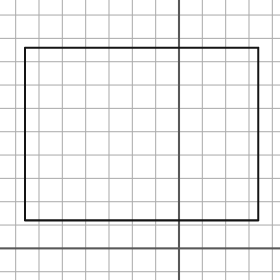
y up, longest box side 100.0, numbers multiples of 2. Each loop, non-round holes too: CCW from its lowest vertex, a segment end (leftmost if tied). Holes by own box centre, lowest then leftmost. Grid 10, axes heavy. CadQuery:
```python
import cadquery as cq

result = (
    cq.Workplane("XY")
    .moveTo(-66.0, 12.0)
    .lineTo(34.0, 12.0)
    .lineTo(34.0, 86.0)
    .lineTo(-66.0, 86.0)
    .close()
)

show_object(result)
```